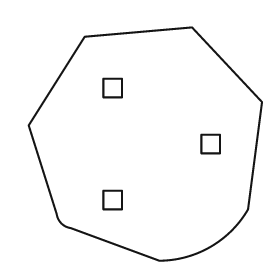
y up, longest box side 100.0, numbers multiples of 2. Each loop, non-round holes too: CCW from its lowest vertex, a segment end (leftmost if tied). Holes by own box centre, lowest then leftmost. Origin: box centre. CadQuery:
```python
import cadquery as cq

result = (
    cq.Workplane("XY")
    .moveTo(6.0, -50.0)
    .threePointArc((28.0, -44.0), (44.0, -28.0))
    .lineTo(50.0, 18.0)
    .lineTo(20.0, 50.0)
    .lineTo(-26.0, 46.0)
    .lineTo(-50.0, 8.0)
    .lineTo(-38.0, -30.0)
    .threePointArc((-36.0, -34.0), (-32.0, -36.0))
    .close()
    .moveTo(-18.0, -28.0)
    .lineTo(-10.0, -28.0)
    .lineTo(-10.0, -20.0)
    .lineTo(-18.0, -20.0)
    .close()
    .moveTo(24.0, -4.0)
    .lineTo(32.0, -4.0)
    .lineTo(32.0, 4.0)
    .lineTo(24.0, 4.0)
    .close()
    .moveTo(-18.0, 20.0)
    .lineTo(-10.0, 20.0)
    .lineTo(-10.0, 28.0)
    .lineTo(-18.0, 28.0)
    .close()
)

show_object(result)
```